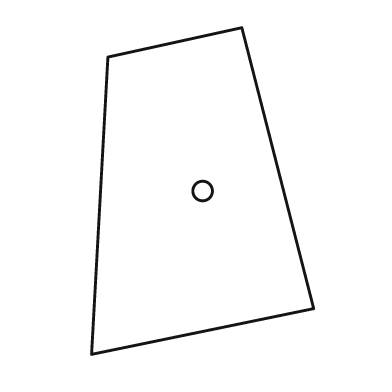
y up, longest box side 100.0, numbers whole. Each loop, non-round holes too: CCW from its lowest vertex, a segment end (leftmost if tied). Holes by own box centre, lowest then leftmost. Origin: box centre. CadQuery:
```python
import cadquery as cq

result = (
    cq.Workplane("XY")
    .moveTo(-34.0, -50.0)
    .lineTo(34.0, -36.0)
    .lineTo(12.0, 50.0)
    .lineTo(-29.0, 41.0)
    .close()
    .moveTo(0.0, 0.0)
    .circle(3.0)
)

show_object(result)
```